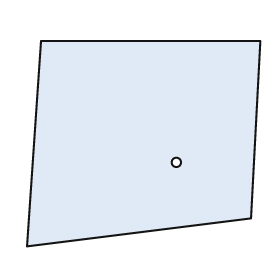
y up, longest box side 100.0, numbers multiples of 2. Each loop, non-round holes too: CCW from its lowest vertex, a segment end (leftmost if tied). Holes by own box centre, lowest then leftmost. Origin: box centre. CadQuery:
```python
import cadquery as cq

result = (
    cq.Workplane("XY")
    .moveTo(-50.0, -44.0)
    .lineTo(46.0, -32.0)
    .lineTo(50.0, 44.0)
    .lineTo(-44.0, 44.0)
    .close()
    .moveTo(14.0, -8.0)
    .circle(2.0)
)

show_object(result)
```